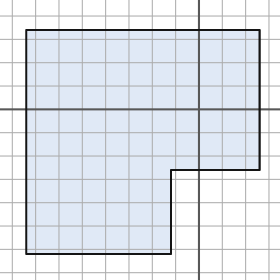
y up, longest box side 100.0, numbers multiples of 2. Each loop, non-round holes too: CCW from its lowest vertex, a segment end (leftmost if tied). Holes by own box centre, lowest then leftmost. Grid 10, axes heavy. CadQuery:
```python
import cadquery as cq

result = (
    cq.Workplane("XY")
    .moveTo(-74.0, -62.0)
    .lineTo(-12.0, -62.0)
    .lineTo(-12.0, -26.0)
    .lineTo(26.0, -26.0)
    .lineTo(26.0, 34.0)
    .lineTo(-74.0, 34.0)
    .close()
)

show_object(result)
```